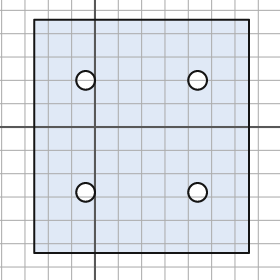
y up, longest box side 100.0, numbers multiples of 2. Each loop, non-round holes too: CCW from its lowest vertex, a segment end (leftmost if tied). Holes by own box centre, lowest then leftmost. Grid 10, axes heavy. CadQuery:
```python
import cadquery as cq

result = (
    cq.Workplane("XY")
    .moveTo(-26.0, -54.0)
    .lineTo(66.0, -54.0)
    .lineTo(66.0, 46.0)
    .lineTo(-26.0, 46.0)
    .close()
    .moveTo(-4.0, -28.0)
    .circle(4.0)
    .moveTo(44.0, -28.0)
    .circle(4.0)
    .moveTo(-4.0, 20.0)
    .circle(4.0)
    .moveTo(44.0, 20.0)
    .circle(4.0)
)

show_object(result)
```